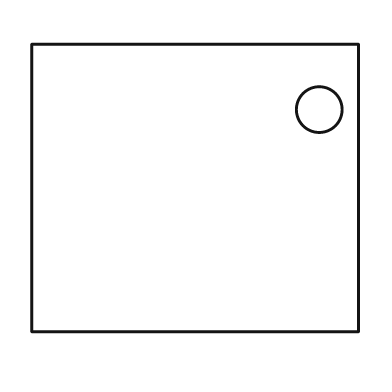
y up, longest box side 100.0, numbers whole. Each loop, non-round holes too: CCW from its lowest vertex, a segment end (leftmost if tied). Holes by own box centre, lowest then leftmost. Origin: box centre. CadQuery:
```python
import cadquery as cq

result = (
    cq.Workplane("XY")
    .moveTo(-50.0, -44.0)
    .lineTo(50.0, -44.0)
    .lineTo(50.0, 44.0)
    .lineTo(-50.0, 44.0)
    .close()
    .moveTo(38.0, 24.0)
    .circle(7.0)
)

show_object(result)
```